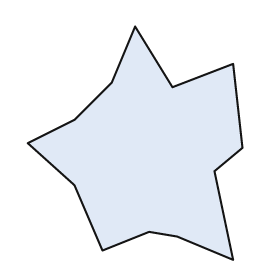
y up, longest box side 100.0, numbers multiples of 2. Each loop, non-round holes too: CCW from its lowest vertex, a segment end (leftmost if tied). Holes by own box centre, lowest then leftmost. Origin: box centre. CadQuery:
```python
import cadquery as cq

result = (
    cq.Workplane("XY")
    .moveTo(42.0, -50.0)
    .lineTo(34.0, -12.0)
    .lineTo(46.0, -2.0)
    .lineTo(42.0, 34.0)
    .lineTo(16.0, 24.0)
    .lineTo(0.0, 50.0)
    .lineTo(-10.0, 26.0)
    .lineTo(-26.0, 10.0)
    .lineTo(-46.0, 0.0)
    .lineTo(-26.0, -18.0)
    .lineTo(-14.0, -46.0)
    .lineTo(6.0, -38.0)
    .lineTo(18.0, -40.0)
    .close()
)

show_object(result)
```